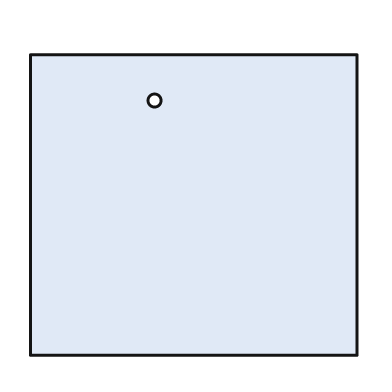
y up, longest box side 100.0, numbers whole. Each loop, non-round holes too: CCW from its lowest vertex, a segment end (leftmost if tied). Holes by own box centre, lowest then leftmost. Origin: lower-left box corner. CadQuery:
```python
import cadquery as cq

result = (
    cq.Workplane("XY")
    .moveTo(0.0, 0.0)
    .lineTo(100.0, 0.0)
    .lineTo(100.0, 92.0)
    .lineTo(0.0, 92.0)
    .close()
    .moveTo(38.0, 78.0)
    .circle(2.0)
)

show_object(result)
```